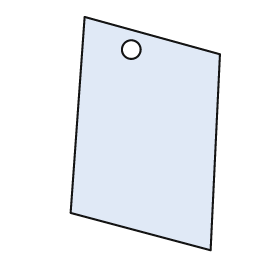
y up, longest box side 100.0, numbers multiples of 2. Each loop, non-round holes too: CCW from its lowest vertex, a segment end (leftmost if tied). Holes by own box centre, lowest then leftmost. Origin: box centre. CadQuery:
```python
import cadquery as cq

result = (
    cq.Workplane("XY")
    .moveTo(28.0, -50.0)
    .lineTo(32.0, 34.0)
    .lineTo(-26.0, 50.0)
    .lineTo(-32.0, -34.0)
    .close()
    .moveTo(-6.0, 36.0)
    .circle(4.0)
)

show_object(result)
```